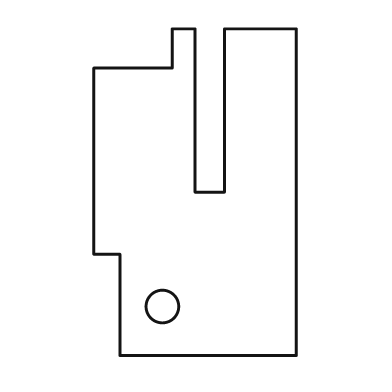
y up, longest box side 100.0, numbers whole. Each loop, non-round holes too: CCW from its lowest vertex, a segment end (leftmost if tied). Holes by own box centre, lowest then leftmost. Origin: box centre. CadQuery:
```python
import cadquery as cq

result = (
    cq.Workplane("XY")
    .moveTo(-23.0, -50.0)
    .lineTo(31.0, -50.0)
    .lineTo(31.0, 50.0)
    .lineTo(9.0, 50.0)
    .lineTo(9.0, 0.0)
    .lineTo(0.0, 0.0)
    .lineTo(0.0, 50.0)
    .lineTo(-7.0, 50.0)
    .lineTo(-7.0, 38.0)
    .lineTo(-31.0, 38.0)
    .lineTo(-31.0, -19.0)
    .lineTo(-23.0, -19.0)
    .close()
    .moveTo(-10.0, -35.0)
    .circle(5.0)
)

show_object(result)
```